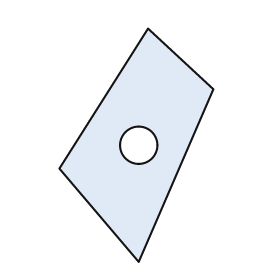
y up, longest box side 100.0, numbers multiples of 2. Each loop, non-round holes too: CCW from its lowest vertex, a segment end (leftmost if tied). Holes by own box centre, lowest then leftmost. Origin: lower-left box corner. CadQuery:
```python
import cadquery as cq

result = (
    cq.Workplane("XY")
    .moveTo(34.0, 0.0)
    .lineTo(66.0, 74.0)
    .lineTo(38.0, 100.0)
    .lineTo(0.0, 40.0)
    .close()
    .moveTo(34.0, 50.0)
    .circle(8.0)
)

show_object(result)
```